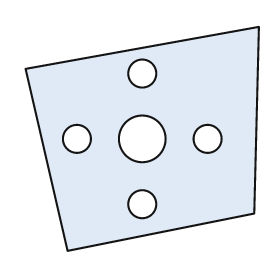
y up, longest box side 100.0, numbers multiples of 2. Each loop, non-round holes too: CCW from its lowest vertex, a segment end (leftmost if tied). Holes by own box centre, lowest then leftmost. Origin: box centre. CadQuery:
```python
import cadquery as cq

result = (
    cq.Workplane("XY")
    .moveTo(-32.0, -48.0)
    .lineTo(48.0, -32.0)
    .lineTo(50.0, 48.0)
    .lineTo(-50.0, 30.0)
    .close()
    .moveTo(0.0, -28.0)
    .circle(6.0)
    .moveTo(-28.0, 0.0)
    .circle(6.0)
    .moveTo(0.0, 0.0)
    .circle(10.0)
    .moveTo(28.0, 0.0)
    .circle(6.0)
    .moveTo(0.0, 28.0)
    .circle(6.0)
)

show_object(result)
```